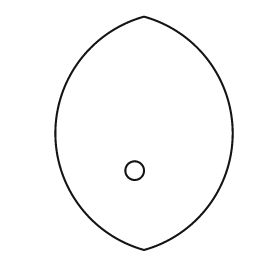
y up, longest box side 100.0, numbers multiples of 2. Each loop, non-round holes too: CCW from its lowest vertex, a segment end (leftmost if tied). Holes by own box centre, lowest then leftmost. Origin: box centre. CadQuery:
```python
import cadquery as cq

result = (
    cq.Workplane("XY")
    .moveTo(0.0, -50.0)
    .threePointArc((38.0, 0.0), (0.0, 50.0))
    .threePointArc((-38.0, 0.0), (0.0, -50.0))
    .close()
    .moveTo(-4.0, -16.0)
    .circle(4.0)
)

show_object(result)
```